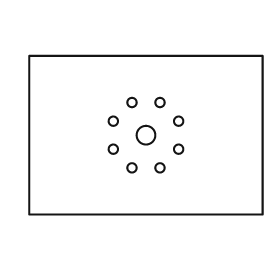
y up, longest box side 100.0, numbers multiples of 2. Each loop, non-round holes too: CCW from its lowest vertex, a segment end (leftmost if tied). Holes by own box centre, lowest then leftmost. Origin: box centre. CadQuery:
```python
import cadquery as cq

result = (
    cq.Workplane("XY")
    .moveTo(-50.0, -34.0)
    .lineTo(50.0, -34.0)
    .lineTo(50.0, 34.0)
    .lineTo(-50.0, 34.0)
    .close()
    .moveTo(-6.0, -14.0)
    .circle(2.0)
    .moveTo(6.0, -14.0)
    .circle(2.0)
    .moveTo(-14.0, -6.0)
    .circle(2.0)
    .moveTo(14.0, -6.0)
    .circle(2.0)
    .moveTo(0.0, 0.0)
    .circle(4.0)
    .moveTo(-14.0, 6.0)
    .circle(2.0)
    .moveTo(14.0, 6.0)
    .circle(2.0)
    .moveTo(-6.0, 14.0)
    .circle(2.0)
    .moveTo(6.0, 14.0)
    .circle(2.0)
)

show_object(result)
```